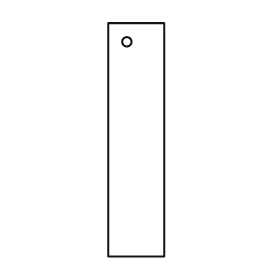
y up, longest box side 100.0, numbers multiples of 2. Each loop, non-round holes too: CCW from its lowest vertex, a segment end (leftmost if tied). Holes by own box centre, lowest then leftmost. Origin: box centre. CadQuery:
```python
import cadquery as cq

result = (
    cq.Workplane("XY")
    .moveTo(-12.0, -50.0)
    .lineTo(12.0, -50.0)
    .lineTo(12.0, 50.0)
    .lineTo(-12.0, 50.0)
    .close()
    .moveTo(-4.0, 42.0)
    .circle(2.0)
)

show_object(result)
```